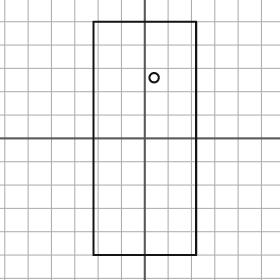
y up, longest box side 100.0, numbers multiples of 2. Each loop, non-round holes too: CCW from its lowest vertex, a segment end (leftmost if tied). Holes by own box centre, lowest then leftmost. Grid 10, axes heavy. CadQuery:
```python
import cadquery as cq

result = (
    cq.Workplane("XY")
    .moveTo(-22.0, -50.0)
    .lineTo(22.0, -50.0)
    .lineTo(22.0, 50.0)
    .lineTo(-22.0, 50.0)
    .close()
    .moveTo(4.0, 26.0)
    .circle(2.0)
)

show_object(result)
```